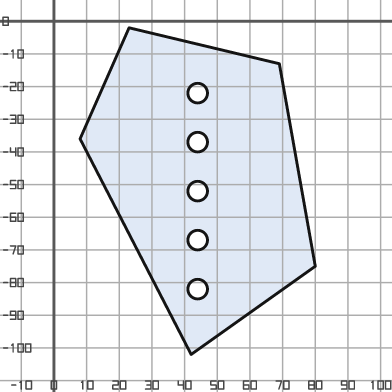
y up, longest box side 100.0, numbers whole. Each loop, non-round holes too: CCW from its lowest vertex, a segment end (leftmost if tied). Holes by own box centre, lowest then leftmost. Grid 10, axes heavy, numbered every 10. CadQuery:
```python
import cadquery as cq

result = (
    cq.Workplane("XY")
    .moveTo(42.0, -102.0)
    .lineTo(80.0, -75.0)
    .lineTo(69.0, -13.0)
    .lineTo(23.0, -2.0)
    .lineTo(8.0, -36.0)
    .close()
    .moveTo(44.0, -82.0)
    .circle(3.0)
    .moveTo(44.0, -67.0)
    .circle(3.0)
    .moveTo(44.0, -52.0)
    .circle(3.0)
    .moveTo(44.0, -37.0)
    .circle(3.0)
    .moveTo(44.0, -22.0)
    .circle(3.0)
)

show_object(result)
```